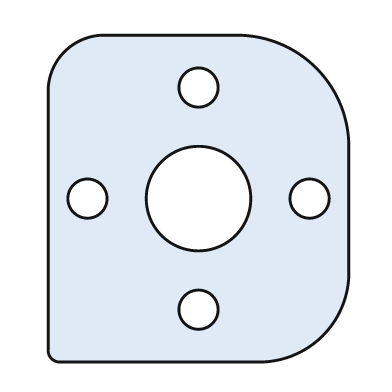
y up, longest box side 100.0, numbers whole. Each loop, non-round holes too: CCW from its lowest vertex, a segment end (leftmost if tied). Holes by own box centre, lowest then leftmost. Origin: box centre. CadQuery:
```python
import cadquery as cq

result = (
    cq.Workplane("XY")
    .moveTo(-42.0, -50.0)
    .lineTo(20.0, -50.0)
    .threePointArc((38.0, -42.0), (46.0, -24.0))
    .lineTo(46.0, 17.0)
    .threePointArc((36.0, 40.0), (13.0, 50.0))
    .lineTo(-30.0, 50.0)
    .threePointArc((-41.0, 45.0), (-46.0, 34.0))
    .lineTo(-46.0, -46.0)
    .threePointArc((-45.0, -49.0), (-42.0, -50.0))
    .close()
    .moveTo(0.0, -34.0)
    .circle(6.0)
    .moveTo(-34.0, 0.0)
    .circle(6.0)
    .moveTo(0.0, 0.0)
    .circle(16.0)
    .moveTo(34.0, 0.0)
    .circle(6.0)
    .moveTo(0.0, 34.0)
    .circle(6.0)
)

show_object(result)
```